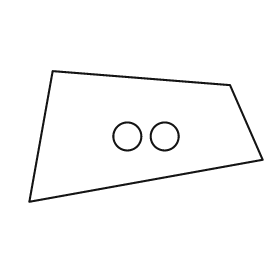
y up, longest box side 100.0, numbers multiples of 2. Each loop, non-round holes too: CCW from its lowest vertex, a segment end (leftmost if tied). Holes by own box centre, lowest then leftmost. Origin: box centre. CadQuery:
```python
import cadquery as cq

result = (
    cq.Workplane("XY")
    .moveTo(-50.0, -28.0)
    .lineTo(50.0, -10.0)
    .lineTo(36.0, 22.0)
    .lineTo(-40.0, 28.0)
    .close()
    .moveTo(-8.0, 0.0)
    .circle(6.0)
    .moveTo(8.0, 0.0)
    .circle(6.0)
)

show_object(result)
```